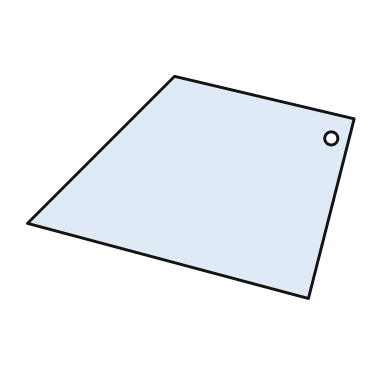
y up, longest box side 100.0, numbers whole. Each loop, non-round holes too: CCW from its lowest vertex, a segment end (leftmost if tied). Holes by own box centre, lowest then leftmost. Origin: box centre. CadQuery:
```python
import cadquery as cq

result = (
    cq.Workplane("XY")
    .moveTo(36.0, -34.0)
    .lineTo(50.0, 21.0)
    .lineTo(-5.0, 34.0)
    .lineTo(-50.0, -11.0)
    .close()
    .moveTo(43.0, 15.0)
    .circle(2.0)
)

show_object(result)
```